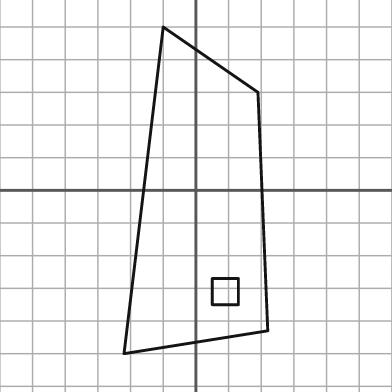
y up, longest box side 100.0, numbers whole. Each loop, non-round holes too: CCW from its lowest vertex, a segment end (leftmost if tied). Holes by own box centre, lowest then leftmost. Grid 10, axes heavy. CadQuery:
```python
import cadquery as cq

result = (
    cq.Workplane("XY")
    .moveTo(-22.0, -50.0)
    .lineTo(22.0, -43.0)
    .lineTo(19.0, 30.0)
    .lineTo(-10.0, 50.0)
    .close()
    .moveTo(5.0, -35.0)
    .lineTo(13.0, -35.0)
    .lineTo(13.0, -27.0)
    .lineTo(5.0, -27.0)
    .close()
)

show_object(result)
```